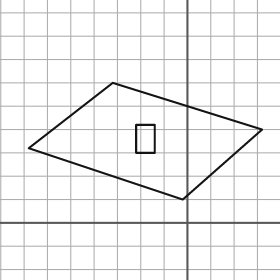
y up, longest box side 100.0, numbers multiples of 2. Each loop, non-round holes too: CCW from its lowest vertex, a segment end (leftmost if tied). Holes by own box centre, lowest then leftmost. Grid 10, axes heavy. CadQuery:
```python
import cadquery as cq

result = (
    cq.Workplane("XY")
    .moveTo(-2.0, 10.0)
    .lineTo(32.0, 40.0)
    .lineTo(-32.0, 60.0)
    .lineTo(-68.0, 32.0)
    .close()
    .moveTo(-22.0, 30.0)
    .lineTo(-14.0, 30.0)
    .lineTo(-14.0, 42.0)
    .lineTo(-22.0, 42.0)
    .close()
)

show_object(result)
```